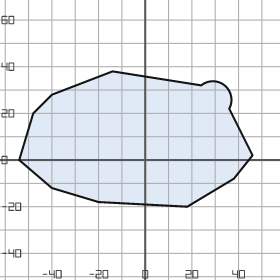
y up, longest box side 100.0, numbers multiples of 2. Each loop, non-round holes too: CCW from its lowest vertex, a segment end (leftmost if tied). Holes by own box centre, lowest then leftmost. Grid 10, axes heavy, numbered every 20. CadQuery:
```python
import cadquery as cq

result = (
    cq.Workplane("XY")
    .moveTo(18.0, -20.0)
    .lineTo(38.0, -8.0)
    .lineTo(46.0, 2.0)
    .lineTo(36.0, 22.0)
    .threePointArc((34.0, 32.0), (24.0, 32.0))
    .lineTo(-14.0, 38.0)
    .lineTo(-40.0, 28.0)
    .lineTo(-48.0, 20.0)
    .lineTo(-54.0, 0.0)
    .lineTo(-40.0, -12.0)
    .lineTo(-20.0, -18.0)
    .close()
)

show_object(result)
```